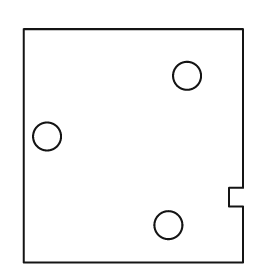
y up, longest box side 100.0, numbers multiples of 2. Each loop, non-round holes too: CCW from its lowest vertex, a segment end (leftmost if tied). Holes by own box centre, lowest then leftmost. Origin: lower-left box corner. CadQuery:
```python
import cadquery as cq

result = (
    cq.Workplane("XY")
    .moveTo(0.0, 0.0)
    .lineTo(94.0, 0.0)
    .lineTo(94.0, 24.0)
    .lineTo(88.0, 24.0)
    .lineTo(88.0, 32.0)
    .lineTo(94.0, 32.0)
    .lineTo(94.0, 100.0)
    .lineTo(0.0, 100.0)
    .close()
    .moveTo(62.0, 16.0)
    .circle(6.0)
    .moveTo(10.0, 54.0)
    .circle(6.0)
    .moveTo(70.0, 80.0)
    .circle(6.0)
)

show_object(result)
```